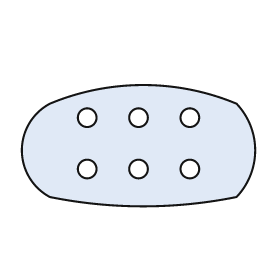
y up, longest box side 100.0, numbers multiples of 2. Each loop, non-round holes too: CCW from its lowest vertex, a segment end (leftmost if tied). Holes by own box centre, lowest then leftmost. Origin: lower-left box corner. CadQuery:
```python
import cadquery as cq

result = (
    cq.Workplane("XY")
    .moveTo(12.0, 4.0)
    .threePointArc((52.0, 0.0), (92.0, 4.0))
    .threePointArc((100.0, 24.0), (92.0, 44.0))
    .threePointArc((52.0, 52.0), (12.0, 44.0))
    .threePointArc((0.0, 24.0), (12.0, 4.0))
    .close()
    .moveTo(28.0, 16.0)
    .circle(4.0)
    .moveTo(50.0, 16.0)
    .circle(4.0)
    .moveTo(72.0, 16.0)
    .circle(4.0)
    .moveTo(28.0, 38.0)
    .circle(4.0)
    .moveTo(50.0, 38.0)
    .circle(4.0)
    .moveTo(72.0, 38.0)
    .circle(4.0)
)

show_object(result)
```